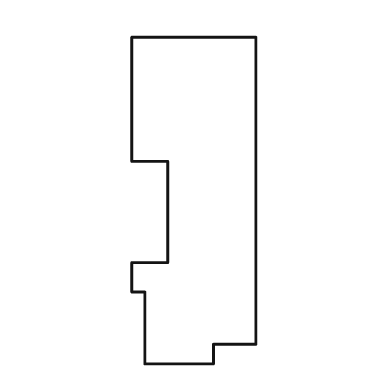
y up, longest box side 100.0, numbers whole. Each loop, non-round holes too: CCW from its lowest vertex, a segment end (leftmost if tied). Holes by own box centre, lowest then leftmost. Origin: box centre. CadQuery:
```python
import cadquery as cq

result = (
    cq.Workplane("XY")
    .moveTo(-15.0, -50.0)
    .lineTo(6.0, -50.0)
    .lineTo(6.0, -44.0)
    .lineTo(19.0, -44.0)
    .lineTo(19.0, 50.0)
    .lineTo(-19.0, 50.0)
    .lineTo(-19.0, 12.0)
    .lineTo(-8.0, 12.0)
    .lineTo(-8.0, -19.0)
    .lineTo(-19.0, -19.0)
    .lineTo(-19.0, -28.0)
    .lineTo(-15.0, -28.0)
    .close()
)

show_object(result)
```